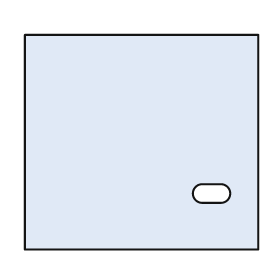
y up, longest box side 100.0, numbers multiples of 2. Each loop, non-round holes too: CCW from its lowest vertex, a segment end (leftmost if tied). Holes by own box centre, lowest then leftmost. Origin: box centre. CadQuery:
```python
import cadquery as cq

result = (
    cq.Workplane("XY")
    .moveTo(-50.0, -46.0)
    .lineTo(50.0, -46.0)
    .lineTo(50.0, 46.0)
    .lineTo(-50.0, 46.0)
    .close()
    .moveTo(26.0, -26.0)
    .lineTo(34.0, -26.0)
    .threePointArc((38.0, -22.0), (34.0, -18.0))
    .lineTo(26.0, -18.0)
    .threePointArc((22.0, -22.0), (26.0, -26.0))
    .close()
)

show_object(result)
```